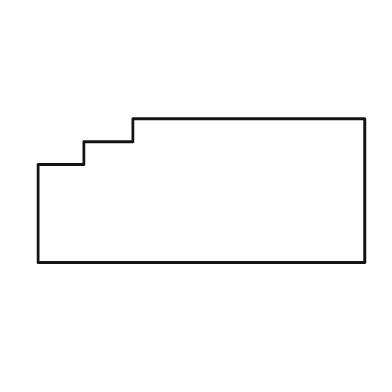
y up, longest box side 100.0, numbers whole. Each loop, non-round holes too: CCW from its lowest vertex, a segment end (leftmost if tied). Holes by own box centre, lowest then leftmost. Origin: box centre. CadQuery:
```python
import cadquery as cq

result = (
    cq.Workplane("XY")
    .moveTo(-50.0, -22.0)
    .lineTo(50.0, -22.0)
    .lineTo(50.0, 22.0)
    .lineTo(-21.0, 22.0)
    .lineTo(-21.0, 15.0)
    .lineTo(-36.0, 15.0)
    .lineTo(-36.0, 8.0)
    .lineTo(-50.0, 8.0)
    .close()
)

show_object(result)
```